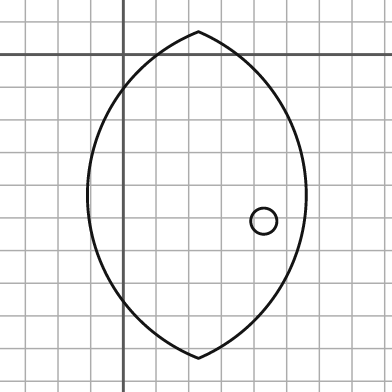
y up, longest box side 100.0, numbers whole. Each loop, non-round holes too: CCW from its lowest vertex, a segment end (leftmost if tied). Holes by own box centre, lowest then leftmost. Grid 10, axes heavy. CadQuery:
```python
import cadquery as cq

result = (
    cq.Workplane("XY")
    .moveTo(23.0, -93.0)
    .threePointArc((56.0, -43.0), (23.0, 7.0))
    .threePointArc((-11.0, -43.0), (23.0, -93.0))
    .close()
    .moveTo(43.0, -51.0)
    .circle(4.0)
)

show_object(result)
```